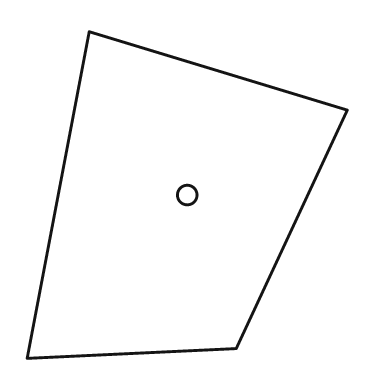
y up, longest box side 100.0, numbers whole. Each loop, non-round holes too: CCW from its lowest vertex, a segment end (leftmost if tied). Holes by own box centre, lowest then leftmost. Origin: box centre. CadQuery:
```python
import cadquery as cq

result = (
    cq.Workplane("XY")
    .moveTo(-49.0, -50.0)
    .lineTo(15.0, -47.0)
    .lineTo(49.0, 26.0)
    .lineTo(-30.0, 50.0)
    .close()
    .moveTo(0.0, 0.0)
    .circle(3.0)
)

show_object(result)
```